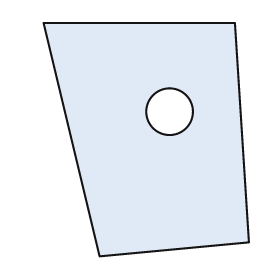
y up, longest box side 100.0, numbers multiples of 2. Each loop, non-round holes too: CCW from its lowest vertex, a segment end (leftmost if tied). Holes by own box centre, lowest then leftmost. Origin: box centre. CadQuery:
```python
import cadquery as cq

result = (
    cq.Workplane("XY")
    .moveTo(-20.0, -50.0)
    .lineTo(44.0, -44.0)
    .lineTo(38.0, 50.0)
    .lineTo(-44.0, 50.0)
    .close()
    .moveTo(10.0, 12.0)
    .circle(10.0)
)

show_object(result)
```